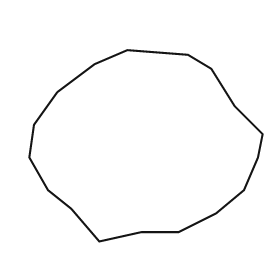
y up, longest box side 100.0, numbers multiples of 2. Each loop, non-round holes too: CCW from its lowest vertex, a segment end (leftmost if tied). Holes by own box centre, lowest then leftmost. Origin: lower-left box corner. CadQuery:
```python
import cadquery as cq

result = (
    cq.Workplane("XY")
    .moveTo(30.0, 0.0)
    .lineTo(48.0, 4.0)
    .lineTo(64.0, 4.0)
    .lineTo(80.0, 12.0)
    .lineTo(92.0, 22.0)
    .lineTo(98.0, 36.0)
    .lineTo(100.0, 46.0)
    .lineTo(88.0, 58.0)
    .lineTo(78.0, 74.0)
    .lineTo(68.0, 80.0)
    .lineTo(42.0, 82.0)
    .lineTo(28.0, 76.0)
    .lineTo(12.0, 64.0)
    .lineTo(2.0, 50.0)
    .lineTo(0.0, 36.0)
    .lineTo(8.0, 22.0)
    .lineTo(18.0, 14.0)
    .close()
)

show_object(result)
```